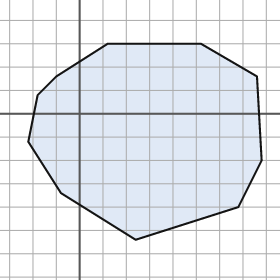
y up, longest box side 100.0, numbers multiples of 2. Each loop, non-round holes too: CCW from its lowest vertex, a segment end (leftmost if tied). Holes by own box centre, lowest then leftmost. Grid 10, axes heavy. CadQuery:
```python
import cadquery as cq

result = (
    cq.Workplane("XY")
    .moveTo(24.0, -54.0)
    .lineTo(68.0, -40.0)
    .lineTo(78.0, -20.0)
    .lineTo(76.0, 16.0)
    .lineTo(52.0, 30.0)
    .lineTo(12.0, 30.0)
    .lineTo(-10.0, 16.0)
    .lineTo(-18.0, 8.0)
    .lineTo(-22.0, -12.0)
    .lineTo(-8.0, -34.0)
    .close()
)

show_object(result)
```